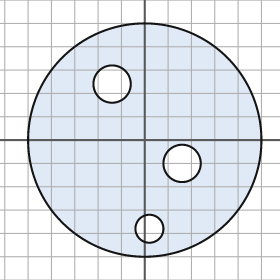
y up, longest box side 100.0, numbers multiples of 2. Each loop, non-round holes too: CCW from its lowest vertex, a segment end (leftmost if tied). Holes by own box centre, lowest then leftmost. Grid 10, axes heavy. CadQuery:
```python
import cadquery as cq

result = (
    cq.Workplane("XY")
    .moveTo(0.0, 0.0)
    .circle(50.0)
    .moveTo(2.0, -38.0)
    .circle(6.0)
    .moveTo(16.0, -10.0)
    .circle(8.0)
    .moveTo(-14.0, 24.0)
    .circle(8.0)
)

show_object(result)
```